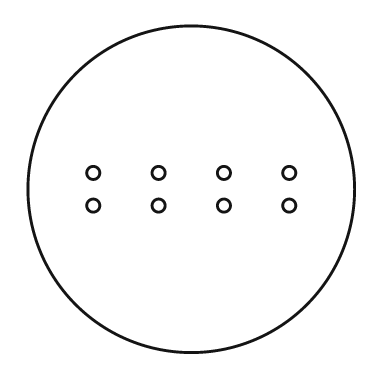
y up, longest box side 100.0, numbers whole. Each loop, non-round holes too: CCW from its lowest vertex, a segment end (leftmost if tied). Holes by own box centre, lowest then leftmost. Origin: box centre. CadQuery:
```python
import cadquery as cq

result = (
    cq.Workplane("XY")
    .moveTo(0.0, 0.0)
    .circle(50.0)
    .moveTo(-30.0, -5.0)
    .circle(2.0)
    .moveTo(-10.0, -5.0)
    .circle(2.0)
    .moveTo(10.0, -5.0)
    .circle(2.0)
    .moveTo(30.0, -5.0)
    .circle(2.0)
    .moveTo(-30.0, 5.0)
    .circle(2.0)
    .moveTo(-10.0, 5.0)
    .circle(2.0)
    .moveTo(10.0, 5.0)
    .circle(2.0)
    .moveTo(30.0, 5.0)
    .circle(2.0)
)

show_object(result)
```